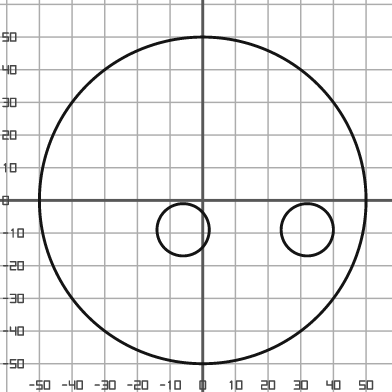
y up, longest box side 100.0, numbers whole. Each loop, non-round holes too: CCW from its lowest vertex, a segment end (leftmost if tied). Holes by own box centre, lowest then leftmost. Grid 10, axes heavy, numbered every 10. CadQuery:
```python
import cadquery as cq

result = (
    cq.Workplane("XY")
    .moveTo(0.0, 0.0)
    .circle(50.0)
    .moveTo(-6.0, -9.0)
    .circle(8.0)
    .moveTo(32.0, -9.0)
    .circle(8.0)
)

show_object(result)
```